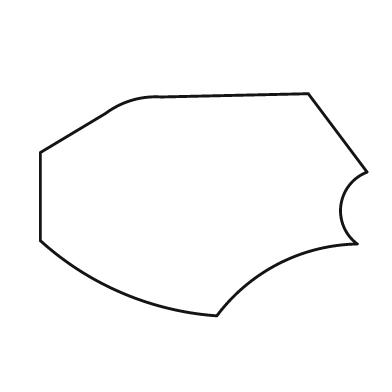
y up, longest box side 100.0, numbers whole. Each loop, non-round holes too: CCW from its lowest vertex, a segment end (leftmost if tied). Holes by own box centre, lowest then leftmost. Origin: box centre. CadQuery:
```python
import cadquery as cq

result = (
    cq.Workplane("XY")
    .moveTo(4.0, -34.0)
    .threePointArc((23.0, -18.0), (47.0, -12.0))
    .threePointArc((42.0, 0.0), (50.0, 10.0))
    .lineTo(32.0, 34.0)
    .lineTo(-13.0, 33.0)
    .threePointArc((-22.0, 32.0), (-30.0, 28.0))
    .lineTo(-50.0, 16.0)
    .lineTo(-50.0, -11.0)
    .threePointArc((-25.0, -27.0), (4.0, -34.0))
    .close()
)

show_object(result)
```